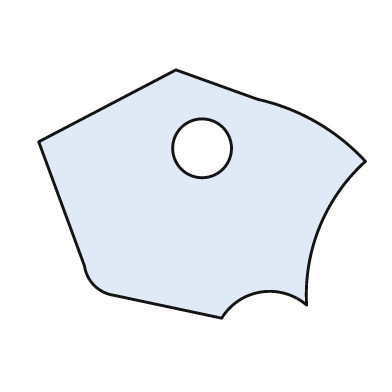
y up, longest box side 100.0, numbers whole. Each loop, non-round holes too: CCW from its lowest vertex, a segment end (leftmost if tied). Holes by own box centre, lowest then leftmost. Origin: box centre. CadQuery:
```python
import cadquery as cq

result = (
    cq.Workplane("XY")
    .moveTo(6.0, -38.0)
    .threePointArc((18.0, -30.0), (32.0, -34.0))
    .threePointArc((36.0, -10.0), (50.0, 10.0))
    .threePointArc((35.0, 22.0), (17.0, 29.0))
    .lineTo(-8.0, 38.0)
    .lineTo(-50.0, 16.0)
    .lineTo(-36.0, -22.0)
    .threePointArc((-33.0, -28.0), (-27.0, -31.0))
    .close()
    .moveTo(0.0, 14.0)
    .circle(9.0)
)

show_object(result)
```